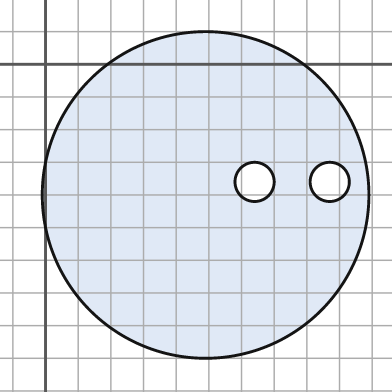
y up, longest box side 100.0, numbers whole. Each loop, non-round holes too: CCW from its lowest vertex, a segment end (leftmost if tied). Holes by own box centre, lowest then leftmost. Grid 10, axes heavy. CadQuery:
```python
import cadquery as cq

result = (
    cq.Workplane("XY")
    .moveTo(49.0, -40.0)
    .circle(50.0)
    .moveTo(64.0, -36.0)
    .circle(6.0)
    .moveTo(87.0, -36.0)
    .circle(6.0)
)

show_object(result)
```